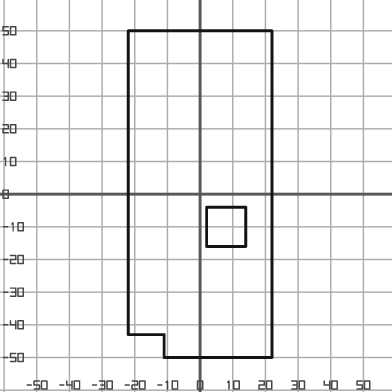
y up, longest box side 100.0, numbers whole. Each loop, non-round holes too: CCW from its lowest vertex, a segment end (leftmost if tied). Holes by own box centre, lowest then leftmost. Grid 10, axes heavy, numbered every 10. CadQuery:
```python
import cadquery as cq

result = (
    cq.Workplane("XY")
    .moveTo(-11.0, -50.0)
    .lineTo(22.0, -50.0)
    .lineTo(22.0, 50.0)
    .lineTo(-22.0, 50.0)
    .lineTo(-22.0, -43.0)
    .lineTo(-11.0, -43.0)
    .close()
    .moveTo(2.0, -16.0)
    .lineTo(14.0, -16.0)
    .lineTo(14.0, -4.0)
    .lineTo(2.0, -4.0)
    .close()
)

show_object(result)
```